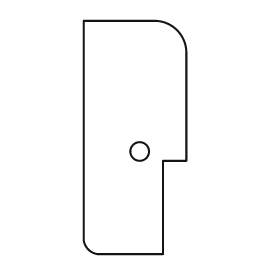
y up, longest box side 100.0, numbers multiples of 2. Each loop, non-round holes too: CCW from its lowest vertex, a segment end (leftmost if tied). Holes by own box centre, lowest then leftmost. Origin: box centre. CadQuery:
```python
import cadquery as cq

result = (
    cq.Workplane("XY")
    .moveTo(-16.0, -50.0)
    .lineTo(12.0, -50.0)
    .lineTo(12.0, -10.0)
    .lineTo(22.0, -10.0)
    .lineTo(22.0, 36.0)
    .threePointArc((18.0, 46.0), (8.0, 50.0))
    .lineTo(-22.0, 50.0)
    .lineTo(-22.0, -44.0)
    .threePointArc((-20.0, -48.0), (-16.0, -50.0))
    .close()
    .moveTo(2.0, -6.0)
    .circle(4.0)
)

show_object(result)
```